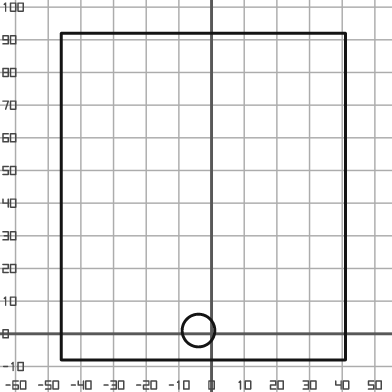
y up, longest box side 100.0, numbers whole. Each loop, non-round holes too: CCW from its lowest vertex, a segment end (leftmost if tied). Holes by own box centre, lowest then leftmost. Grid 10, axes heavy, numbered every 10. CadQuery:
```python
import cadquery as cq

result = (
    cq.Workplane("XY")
    .moveTo(-46.0, -8.0)
    .lineTo(41.0, -8.0)
    .lineTo(41.0, 92.0)
    .lineTo(-46.0, 92.0)
    .close()
    .moveTo(-4.0, 1.0)
    .circle(5.0)
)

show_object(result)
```